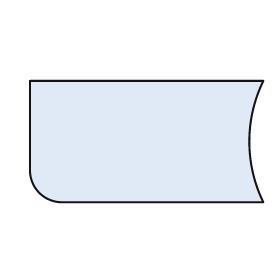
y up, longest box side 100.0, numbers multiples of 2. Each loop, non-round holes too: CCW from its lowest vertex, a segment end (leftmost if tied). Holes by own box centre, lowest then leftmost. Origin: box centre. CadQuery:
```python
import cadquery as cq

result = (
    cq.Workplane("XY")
    .moveTo(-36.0, -26.0)
    .lineTo(50.0, -26.0)
    .threePointArc((44.0, 0.0), (50.0, 26.0))
    .lineTo(-50.0, 26.0)
    .lineTo(-50.0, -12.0)
    .threePointArc((-46.0, -22.0), (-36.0, -26.0))
    .close()
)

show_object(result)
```